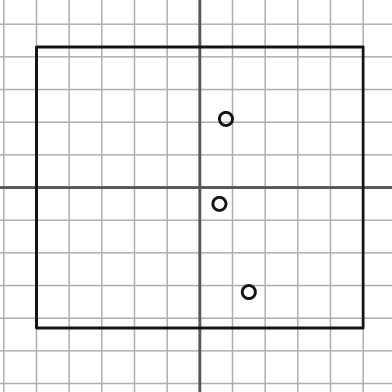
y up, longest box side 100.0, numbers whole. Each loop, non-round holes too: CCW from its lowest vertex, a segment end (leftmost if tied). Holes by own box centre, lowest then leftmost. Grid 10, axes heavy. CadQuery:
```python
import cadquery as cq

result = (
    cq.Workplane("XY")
    .moveTo(-50.0, -43.0)
    .lineTo(50.0, -43.0)
    .lineTo(50.0, 43.0)
    .lineTo(-50.0, 43.0)
    .close()
    .moveTo(15.0, -32.0)
    .circle(2.0)
    .moveTo(6.0, -5.0)
    .circle(2.0)
    .moveTo(8.0, 21.0)
    .circle(2.0)
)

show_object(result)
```